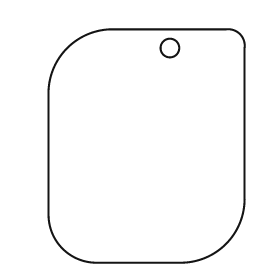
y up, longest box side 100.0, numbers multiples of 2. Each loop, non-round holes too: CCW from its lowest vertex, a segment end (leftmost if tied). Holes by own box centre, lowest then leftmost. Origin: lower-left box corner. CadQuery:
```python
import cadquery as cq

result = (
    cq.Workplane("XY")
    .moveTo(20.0, 0.0)
    .lineTo(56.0, 0.0)
    .threePointArc((76.0, 8.0), (84.0, 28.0))
    .lineTo(84.0, 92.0)
    .threePointArc((82.0, 98.0), (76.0, 100.0))
    .lineTo(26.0, 100.0)
    .threePointArc((8.0, 92.0), (0.0, 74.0))
    .lineTo(0.0, 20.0)
    .threePointArc((6.0, 6.0), (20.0, 0.0))
    .close()
    .moveTo(52.0, 92.0)
    .circle(4.0)
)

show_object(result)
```